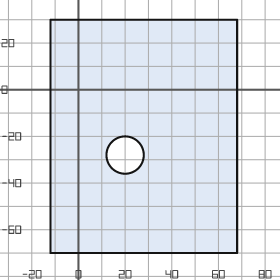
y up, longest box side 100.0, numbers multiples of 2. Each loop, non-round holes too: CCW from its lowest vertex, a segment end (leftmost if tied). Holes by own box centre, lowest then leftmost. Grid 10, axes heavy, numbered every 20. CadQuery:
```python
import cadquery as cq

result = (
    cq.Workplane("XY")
    .moveTo(-12.0, -70.0)
    .lineTo(68.0, -70.0)
    .lineTo(68.0, 30.0)
    .lineTo(-12.0, 30.0)
    .close()
    .moveTo(20.0, -28.0)
    .circle(8.0)
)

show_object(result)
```